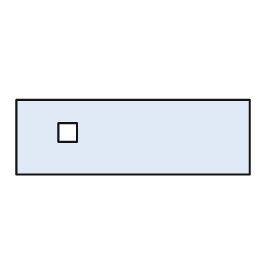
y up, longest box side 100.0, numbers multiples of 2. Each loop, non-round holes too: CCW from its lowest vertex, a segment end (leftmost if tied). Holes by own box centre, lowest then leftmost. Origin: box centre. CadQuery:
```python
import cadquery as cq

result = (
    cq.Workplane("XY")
    .moveTo(-50.0, -16.0)
    .lineTo(50.0, -16.0)
    .lineTo(50.0, 16.0)
    .lineTo(-50.0, 16.0)
    .close()
    .moveTo(-32.0, -2.0)
    .lineTo(-24.0, -2.0)
    .lineTo(-24.0, 6.0)
    .lineTo(-32.0, 6.0)
    .close()
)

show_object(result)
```